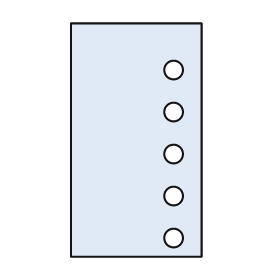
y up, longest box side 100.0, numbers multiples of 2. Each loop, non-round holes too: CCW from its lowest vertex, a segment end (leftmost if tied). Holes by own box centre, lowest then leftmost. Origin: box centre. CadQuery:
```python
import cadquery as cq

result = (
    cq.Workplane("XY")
    .moveTo(-28.0, -50.0)
    .lineTo(28.0, -50.0)
    .lineTo(28.0, 50.0)
    .lineTo(-28.0, 50.0)
    .close()
    .moveTo(16.0, -42.0)
    .circle(4.0)
    .moveTo(16.0, -24.0)
    .circle(4.0)
    .moveTo(16.0, -6.0)
    .circle(4.0)
    .moveTo(16.0, 12.0)
    .circle(4.0)
    .moveTo(16.0, 30.0)
    .circle(4.0)
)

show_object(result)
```